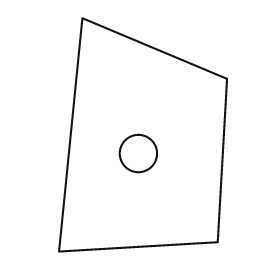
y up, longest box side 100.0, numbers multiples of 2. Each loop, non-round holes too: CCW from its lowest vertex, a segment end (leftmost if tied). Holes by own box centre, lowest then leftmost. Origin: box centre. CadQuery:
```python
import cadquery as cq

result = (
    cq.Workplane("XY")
    .moveTo(-36.0, -50.0)
    .lineTo(32.0, -46.0)
    .lineTo(36.0, 24.0)
    .lineTo(-26.0, 50.0)
    .close()
    .moveTo(-2.0, -8.0)
    .circle(8.0)
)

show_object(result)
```